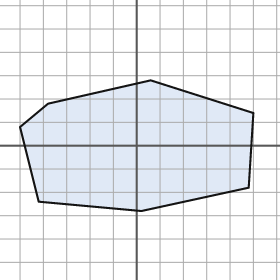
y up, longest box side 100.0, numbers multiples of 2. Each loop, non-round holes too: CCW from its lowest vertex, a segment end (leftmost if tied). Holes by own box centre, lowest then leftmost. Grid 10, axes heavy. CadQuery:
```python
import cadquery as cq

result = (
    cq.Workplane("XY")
    .moveTo(2.0, -28.0)
    .lineTo(48.0, -18.0)
    .lineTo(50.0, 14.0)
    .lineTo(6.0, 28.0)
    .lineTo(-38.0, 18.0)
    .lineTo(-50.0, 8.0)
    .lineTo(-42.0, -24.0)
    .close()
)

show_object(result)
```